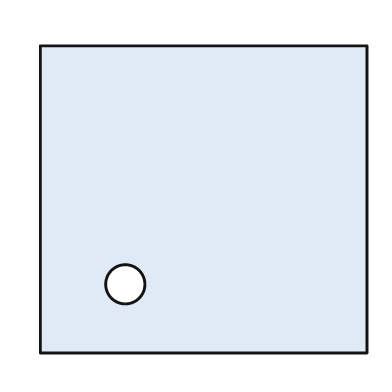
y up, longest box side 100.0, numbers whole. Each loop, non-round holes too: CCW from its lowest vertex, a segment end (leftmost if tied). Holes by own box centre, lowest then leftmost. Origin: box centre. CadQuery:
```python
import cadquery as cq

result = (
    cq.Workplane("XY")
    .moveTo(-50.0, -47.0)
    .lineTo(50.0, -47.0)
    .lineTo(50.0, 47.0)
    .lineTo(-50.0, 47.0)
    .close()
    .moveTo(-24.0, -26.0)
    .circle(6.0)
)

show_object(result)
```